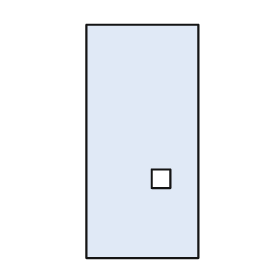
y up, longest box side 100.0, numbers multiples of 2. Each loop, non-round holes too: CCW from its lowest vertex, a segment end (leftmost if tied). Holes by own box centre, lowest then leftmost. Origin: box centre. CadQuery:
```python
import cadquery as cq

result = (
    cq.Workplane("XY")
    .moveTo(-24.0, -50.0)
    .lineTo(24.0, -50.0)
    .lineTo(24.0, 50.0)
    .lineTo(-24.0, 50.0)
    .close()
    .moveTo(4.0, -20.0)
    .lineTo(12.0, -20.0)
    .lineTo(12.0, -12.0)
    .lineTo(4.0, -12.0)
    .close()
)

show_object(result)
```